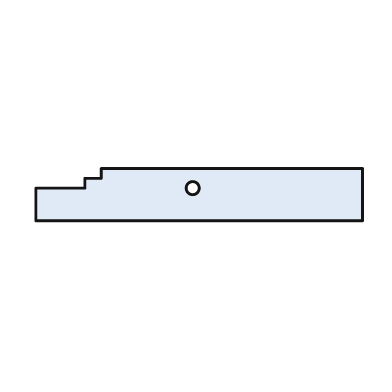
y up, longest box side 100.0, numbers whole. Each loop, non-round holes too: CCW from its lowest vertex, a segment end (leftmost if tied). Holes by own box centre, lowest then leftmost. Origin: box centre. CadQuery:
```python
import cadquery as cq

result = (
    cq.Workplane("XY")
    .moveTo(-50.0, -8.0)
    .lineTo(50.0, -8.0)
    .lineTo(50.0, 8.0)
    .lineTo(-30.0, 8.0)
    .lineTo(-30.0, 5.0)
    .lineTo(-35.0, 5.0)
    .lineTo(-35.0, 2.0)
    .lineTo(-50.0, 2.0)
    .close()
    .moveTo(-2.0, 2.0)
    .circle(2.0)
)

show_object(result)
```